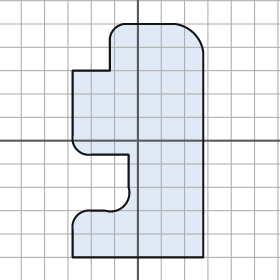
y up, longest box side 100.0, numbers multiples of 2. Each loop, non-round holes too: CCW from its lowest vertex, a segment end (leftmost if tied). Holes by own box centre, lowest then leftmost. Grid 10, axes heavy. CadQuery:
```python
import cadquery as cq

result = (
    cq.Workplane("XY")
    .moveTo(-28.0, -50.0)
    .lineTo(28.0, -50.0)
    .lineTo(28.0, 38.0)
    .threePointArc((24.0, 46.0), (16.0, 50.0))
    .lineTo(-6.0, 50.0)
    .threePointArc((-10.0, 48.0), (-12.0, 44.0))
    .lineTo(-12.0, 30.0)
    .lineTo(-28.0, 30.0)
    .lineTo(-28.0, 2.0)
    .threePointArc((-26.0, -4.0), (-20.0, -6.0))
    .lineTo(-4.0, -6.0)
    .lineTo(-4.0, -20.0)
    .threePointArc((-6.0, -28.0), (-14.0, -30.0))
    .lineTo(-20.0, -30.0)
    .threePointArc((-26.0, -32.0), (-28.0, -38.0))
    .close()
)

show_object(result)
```